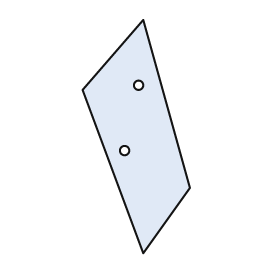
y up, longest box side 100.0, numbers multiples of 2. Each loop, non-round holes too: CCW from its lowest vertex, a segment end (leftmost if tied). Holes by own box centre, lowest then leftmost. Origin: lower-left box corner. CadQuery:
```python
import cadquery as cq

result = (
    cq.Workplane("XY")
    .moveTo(26.0, 0.0)
    .lineTo(46.0, 28.0)
    .lineTo(26.0, 100.0)
    .lineTo(0.0, 70.0)
    .close()
    .moveTo(18.0, 44.0)
    .circle(2.0)
    .moveTo(24.0, 72.0)
    .circle(2.0)
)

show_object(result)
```